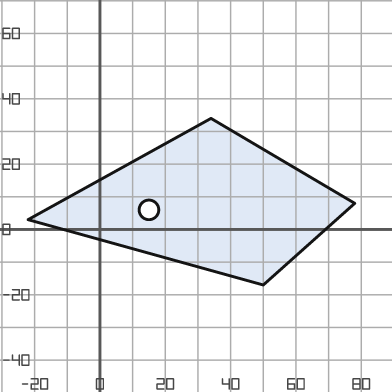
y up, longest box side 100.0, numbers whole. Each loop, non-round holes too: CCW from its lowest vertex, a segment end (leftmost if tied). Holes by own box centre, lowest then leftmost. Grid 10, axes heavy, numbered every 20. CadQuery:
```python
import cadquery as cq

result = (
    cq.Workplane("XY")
    .moveTo(50.0, -17.0)
    .lineTo(78.0, 8.0)
    .lineTo(34.0, 34.0)
    .lineTo(-22.0, 3.0)
    .close()
    .moveTo(15.0, 6.0)
    .circle(3.0)
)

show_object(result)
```